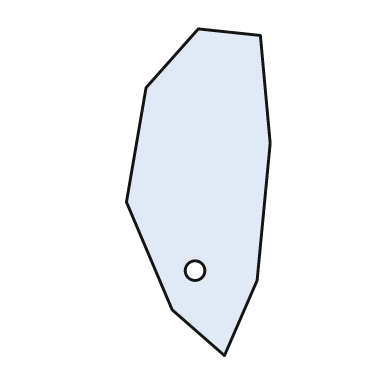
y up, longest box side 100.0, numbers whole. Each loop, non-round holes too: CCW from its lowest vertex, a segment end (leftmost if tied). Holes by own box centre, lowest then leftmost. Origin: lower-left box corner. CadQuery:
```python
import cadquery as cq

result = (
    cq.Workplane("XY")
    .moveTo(30.0, 0.0)
    .lineTo(40.0, 23.0)
    .lineTo(44.0, 65.0)
    .lineTo(41.0, 98.0)
    .lineTo(22.0, 100.0)
    .lineTo(6.0, 82.0)
    .lineTo(0.0, 47.0)
    .lineTo(14.0, 14.0)
    .close()
    .moveTo(21.0, 26.0)
    .circle(3.0)
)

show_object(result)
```